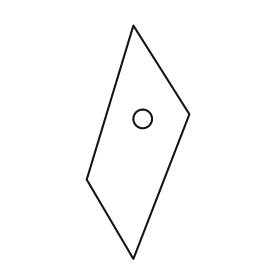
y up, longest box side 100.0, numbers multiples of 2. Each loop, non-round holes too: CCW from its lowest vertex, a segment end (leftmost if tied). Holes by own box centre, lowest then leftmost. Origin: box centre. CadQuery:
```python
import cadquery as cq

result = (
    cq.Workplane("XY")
    .moveTo(-2.0, -50.0)
    .lineTo(22.0, 12.0)
    .lineTo(-2.0, 50.0)
    .lineTo(-22.0, -16.0)
    .close()
    .moveTo(2.0, 10.0)
    .circle(4.0)
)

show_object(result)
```